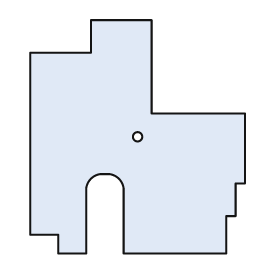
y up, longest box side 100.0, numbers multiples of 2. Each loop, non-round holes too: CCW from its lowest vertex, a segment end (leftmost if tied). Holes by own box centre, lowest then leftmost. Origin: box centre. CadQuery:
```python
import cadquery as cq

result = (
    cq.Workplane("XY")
    .moveTo(-34.0, -50.0)
    .lineTo(-22.0, -50.0)
    .lineTo(-22.0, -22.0)
    .threePointArc((-20.0, -18.0), (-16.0, -16.0))
    .lineTo(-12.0, -16.0)
    .threePointArc((-8.0, -18.0), (-6.0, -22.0))
    .lineTo(-6.0, -50.0)
    .lineTo(38.0, -50.0)
    .lineTo(38.0, -34.0)
    .lineTo(42.0, -34.0)
    .lineTo(42.0, -20.0)
    .lineTo(46.0, -20.0)
    .lineTo(46.0, 10.0)
    .lineTo(6.0, 10.0)
    .lineTo(6.0, 50.0)
    .lineTo(-20.0, 50.0)
    .lineTo(-20.0, 36.0)
    .lineTo(-46.0, 36.0)
    .lineTo(-46.0, -42.0)
    .lineTo(-34.0, -42.0)
    .close()
    .moveTo(0.0, 0.0)
    .circle(2.0)
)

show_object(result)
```